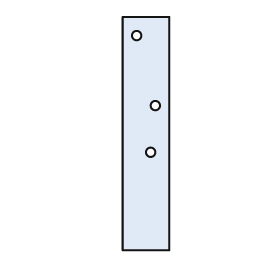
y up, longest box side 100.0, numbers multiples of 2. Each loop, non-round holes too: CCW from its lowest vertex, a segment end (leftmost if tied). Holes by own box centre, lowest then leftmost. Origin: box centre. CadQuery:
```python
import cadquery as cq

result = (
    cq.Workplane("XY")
    .moveTo(-10.0, -50.0)
    .lineTo(10.0, -50.0)
    .lineTo(10.0, 50.0)
    .lineTo(-10.0, 50.0)
    .close()
    .moveTo(2.0, -8.0)
    .circle(2.0)
    .moveTo(4.0, 12.0)
    .circle(2.0)
    .moveTo(-4.0, 42.0)
    .circle(2.0)
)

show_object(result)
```